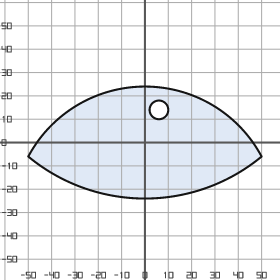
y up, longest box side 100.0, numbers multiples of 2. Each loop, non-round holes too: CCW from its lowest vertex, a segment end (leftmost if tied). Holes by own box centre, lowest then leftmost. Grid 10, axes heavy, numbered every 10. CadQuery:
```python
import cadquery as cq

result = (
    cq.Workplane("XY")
    .moveTo(-50.0, -6.0)
    .threePointArc((0.0, -24.0), (50.0, -6.0))
    .threePointArc((0.0, 24.0), (-50.0, -6.0))
    .close()
    .moveTo(6.0, 14.0)
    .circle(4.0)
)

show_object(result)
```